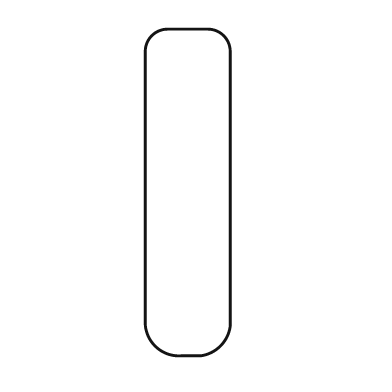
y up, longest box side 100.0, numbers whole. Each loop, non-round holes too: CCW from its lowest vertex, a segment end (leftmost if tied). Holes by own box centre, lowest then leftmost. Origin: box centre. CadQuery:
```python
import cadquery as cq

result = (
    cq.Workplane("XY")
    .moveTo(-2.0, -50.0)
    .lineTo(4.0, -50.0)
    .threePointArc((10.0, -47.0), (13.0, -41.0))
    .lineTo(13.0, 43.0)
    .threePointArc((11.0, 48.0), (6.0, 50.0))
    .lineTo(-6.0, 50.0)
    .threePointArc((-11.0, 48.0), (-13.0, 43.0))
    .lineTo(-13.0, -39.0)
    .threePointArc((-10.0, -47.0), (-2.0, -50.0))
    .close()
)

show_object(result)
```